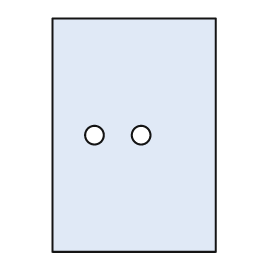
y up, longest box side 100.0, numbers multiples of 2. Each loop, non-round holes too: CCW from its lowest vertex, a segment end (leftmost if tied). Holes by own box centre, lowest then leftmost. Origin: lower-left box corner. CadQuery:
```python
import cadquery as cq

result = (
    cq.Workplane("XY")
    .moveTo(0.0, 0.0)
    .lineTo(70.0, 0.0)
    .lineTo(70.0, 100.0)
    .lineTo(0.0, 100.0)
    .close()
    .moveTo(18.0, 50.0)
    .circle(4.0)
    .moveTo(38.0, 50.0)
    .circle(4.0)
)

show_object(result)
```